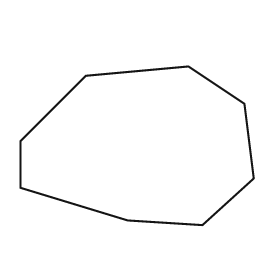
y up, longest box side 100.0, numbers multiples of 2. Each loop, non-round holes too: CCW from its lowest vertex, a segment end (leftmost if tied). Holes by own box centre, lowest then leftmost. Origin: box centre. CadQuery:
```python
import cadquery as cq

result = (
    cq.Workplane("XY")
    .moveTo(28.0, -34.0)
    .lineTo(50.0, -14.0)
    .lineTo(46.0, 18.0)
    .lineTo(22.0, 34.0)
    .lineTo(-22.0, 30.0)
    .lineTo(-50.0, 2.0)
    .lineTo(-50.0, -18.0)
    .lineTo(-4.0, -32.0)
    .close()
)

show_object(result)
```